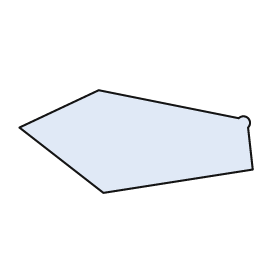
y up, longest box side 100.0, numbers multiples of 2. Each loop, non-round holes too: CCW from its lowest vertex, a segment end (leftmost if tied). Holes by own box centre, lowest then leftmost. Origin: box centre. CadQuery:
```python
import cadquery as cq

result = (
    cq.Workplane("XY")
    .moveTo(-14.0, -22.0)
    .lineTo(50.0, -12.0)
    .lineTo(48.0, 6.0)
    .threePointArc((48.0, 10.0), (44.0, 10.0))
    .lineTo(-16.0, 22.0)
    .lineTo(-50.0, 6.0)
    .close()
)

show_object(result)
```